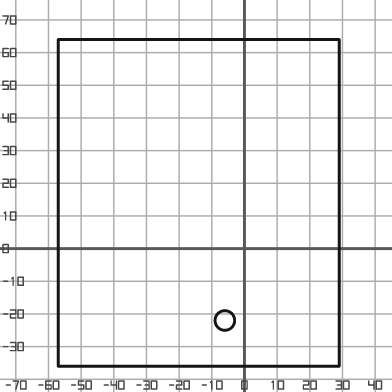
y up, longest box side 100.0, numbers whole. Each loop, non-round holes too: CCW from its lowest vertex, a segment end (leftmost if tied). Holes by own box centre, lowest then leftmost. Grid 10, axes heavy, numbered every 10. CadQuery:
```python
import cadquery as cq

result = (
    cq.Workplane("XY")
    .moveTo(-57.0, -36.0)
    .lineTo(29.0, -36.0)
    .lineTo(29.0, 64.0)
    .lineTo(-57.0, 64.0)
    .close()
    .moveTo(-6.0, -22.0)
    .circle(3.0)
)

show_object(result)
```